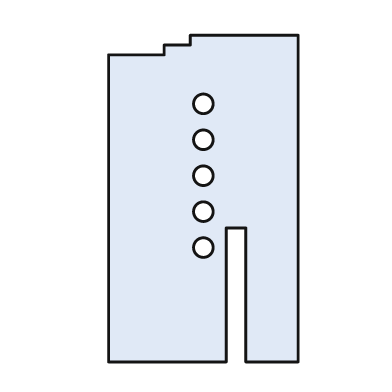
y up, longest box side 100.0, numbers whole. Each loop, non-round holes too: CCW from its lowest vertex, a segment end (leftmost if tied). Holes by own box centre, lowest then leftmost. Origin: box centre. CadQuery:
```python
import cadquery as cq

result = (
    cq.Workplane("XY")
    .moveTo(-29.0, -50.0)
    .lineTo(7.0, -50.0)
    .lineTo(7.0, -9.0)
    .lineTo(13.0, -9.0)
    .lineTo(13.0, -50.0)
    .lineTo(29.0, -50.0)
    .lineTo(29.0, 50.0)
    .lineTo(-4.0, 50.0)
    .lineTo(-4.0, 47.0)
    .lineTo(-12.0, 47.0)
    .lineTo(-12.0, 44.0)
    .lineTo(-29.0, 44.0)
    .close()
    .moveTo(0.0, -15.0)
    .circle(3.0)
    .moveTo(0.0, -4.0)
    .circle(3.0)
    .moveTo(0.0, 7.0)
    .circle(3.0)
    .moveTo(0.0, 18.0)
    .circle(3.0)
    .moveTo(0.0, 29.0)
    .circle(3.0)
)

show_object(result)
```